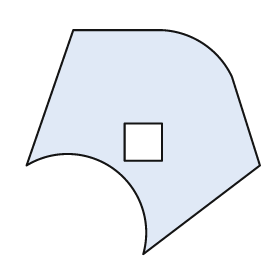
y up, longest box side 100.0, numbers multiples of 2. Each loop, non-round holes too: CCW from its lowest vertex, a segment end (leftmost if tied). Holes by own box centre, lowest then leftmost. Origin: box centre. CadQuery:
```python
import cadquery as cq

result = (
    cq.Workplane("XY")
    .moveTo(0.0, -48.0)
    .lineTo(50.0, -10.0)
    .lineTo(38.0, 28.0)
    .threePointArc((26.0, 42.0), (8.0, 48.0))
    .lineTo(-30.0, 48.0)
    .lineTo(-50.0, -10.0)
    .threePointArc((-12.0, -12.0), (0.0, -48.0))
    .close()
    .moveTo(-8.0, -8.0)
    .lineTo(8.0, -8.0)
    .lineTo(8.0, 8.0)
    .lineTo(-8.0, 8.0)
    .close()
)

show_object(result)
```